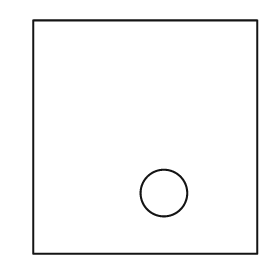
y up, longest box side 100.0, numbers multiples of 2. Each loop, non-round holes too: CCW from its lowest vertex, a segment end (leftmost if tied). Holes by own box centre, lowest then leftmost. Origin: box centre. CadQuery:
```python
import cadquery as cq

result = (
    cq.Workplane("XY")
    .moveTo(-48.0, -50.0)
    .lineTo(48.0, -50.0)
    .lineTo(48.0, 50.0)
    .lineTo(-48.0, 50.0)
    .close()
    .moveTo(8.0, -24.0)
    .circle(10.0)
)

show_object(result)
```